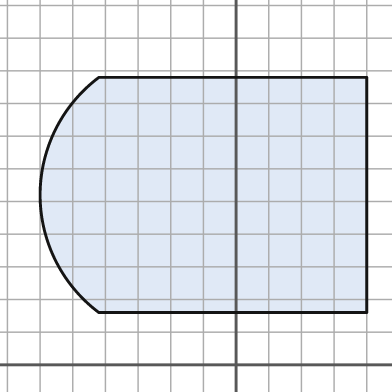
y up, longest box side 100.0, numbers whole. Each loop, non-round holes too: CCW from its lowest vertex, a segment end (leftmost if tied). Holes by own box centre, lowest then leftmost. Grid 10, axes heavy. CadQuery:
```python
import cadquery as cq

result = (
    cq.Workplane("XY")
    .moveTo(-42.0, 16.0)
    .lineTo(40.0, 16.0)
    .lineTo(40.0, 88.0)
    .lineTo(-42.0, 88.0)
    .threePointArc((-60.0, 52.0), (-42.0, 16.0))
    .close()
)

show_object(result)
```